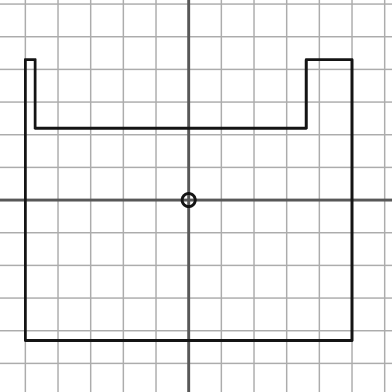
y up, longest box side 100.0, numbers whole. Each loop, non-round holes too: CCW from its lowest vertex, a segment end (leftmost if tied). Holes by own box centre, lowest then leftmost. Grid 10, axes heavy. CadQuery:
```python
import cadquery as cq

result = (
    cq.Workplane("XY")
    .moveTo(-50.0, -43.0)
    .lineTo(50.0, -43.0)
    .lineTo(50.0, 43.0)
    .lineTo(36.0, 43.0)
    .lineTo(36.0, 22.0)
    .lineTo(-47.0, 22.0)
    .lineTo(-47.0, 43.0)
    .lineTo(-50.0, 43.0)
    .close()
    .moveTo(0.0, 0.0)
    .circle(2.0)
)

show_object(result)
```